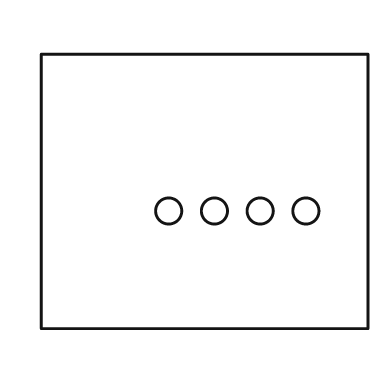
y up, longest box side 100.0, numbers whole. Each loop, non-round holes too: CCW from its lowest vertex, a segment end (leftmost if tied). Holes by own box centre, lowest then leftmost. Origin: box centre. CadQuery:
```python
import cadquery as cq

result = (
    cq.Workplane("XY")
    .moveTo(-50.0, -42.0)
    .lineTo(50.0, -42.0)
    .lineTo(50.0, 42.0)
    .lineTo(-50.0, 42.0)
    .close()
    .moveTo(-11.0, -6.0)
    .circle(4.0)
    .moveTo(3.0, -6.0)
    .circle(4.0)
    .moveTo(17.0, -6.0)
    .circle(4.0)
    .moveTo(31.0, -6.0)
    .circle(4.0)
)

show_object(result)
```